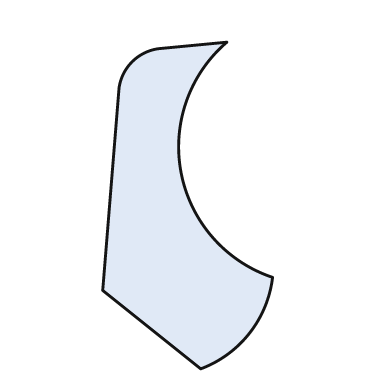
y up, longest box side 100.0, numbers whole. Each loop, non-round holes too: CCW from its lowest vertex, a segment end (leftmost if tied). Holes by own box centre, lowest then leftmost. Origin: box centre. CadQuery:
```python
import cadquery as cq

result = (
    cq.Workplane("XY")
    .moveTo(4.0, -50.0)
    .threePointArc((19.0, -39.0), (26.0, -22.0))
    .threePointArc((-2.0, 10.0), (12.0, 50.0))
    .lineTo(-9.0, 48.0)
    .threePointArc((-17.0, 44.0), (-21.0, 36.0))
    .lineTo(-26.0, -26.0)
    .close()
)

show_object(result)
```